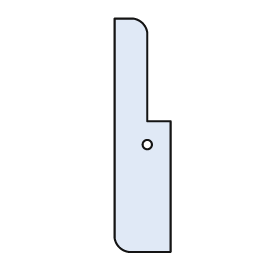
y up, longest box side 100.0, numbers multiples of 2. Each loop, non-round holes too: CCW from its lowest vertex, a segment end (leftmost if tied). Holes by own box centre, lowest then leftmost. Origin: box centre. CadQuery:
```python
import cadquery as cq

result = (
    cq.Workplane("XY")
    .moveTo(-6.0, -50.0)
    .lineTo(12.0, -50.0)
    .lineTo(12.0, 6.0)
    .lineTo(2.0, 6.0)
    .lineTo(2.0, 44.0)
    .threePointArc((0.0, 48.0), (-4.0, 50.0))
    .lineTo(-12.0, 50.0)
    .lineTo(-12.0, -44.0)
    .threePointArc((-10.0, -48.0), (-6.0, -50.0))
    .close()
    .moveTo(2.0, -4.0)
    .circle(2.0)
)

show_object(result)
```